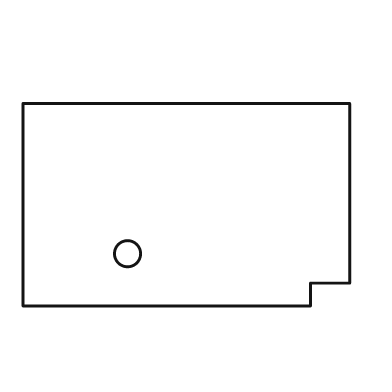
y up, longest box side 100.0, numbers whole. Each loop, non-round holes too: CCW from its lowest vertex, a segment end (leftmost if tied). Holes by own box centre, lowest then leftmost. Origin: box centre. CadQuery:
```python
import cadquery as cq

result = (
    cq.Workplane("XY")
    .moveTo(-50.0, -31.0)
    .lineTo(38.0, -31.0)
    .lineTo(38.0, -24.0)
    .lineTo(50.0, -24.0)
    .lineTo(50.0, 31.0)
    .lineTo(-50.0, 31.0)
    .close()
    .moveTo(-18.0, -15.0)
    .circle(4.0)
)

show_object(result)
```